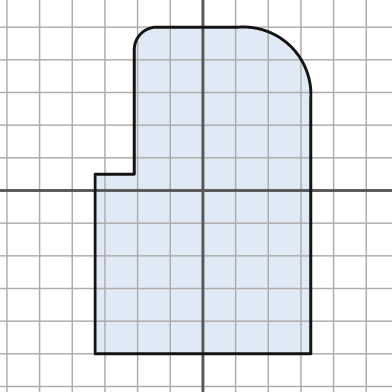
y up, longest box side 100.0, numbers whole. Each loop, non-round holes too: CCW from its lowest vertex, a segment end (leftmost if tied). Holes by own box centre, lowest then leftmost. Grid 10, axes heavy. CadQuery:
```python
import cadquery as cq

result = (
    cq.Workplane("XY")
    .moveTo(-33.0, -50.0)
    .lineTo(33.0, -50.0)
    .lineTo(33.0, 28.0)
    .threePointArc((27.0, 44.0), (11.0, 50.0))
    .lineTo(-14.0, 50.0)
    .threePointArc((-19.0, 48.0), (-21.0, 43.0))
    .lineTo(-21.0, 5.0)
    .lineTo(-33.0, 5.0)
    .close()
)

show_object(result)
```